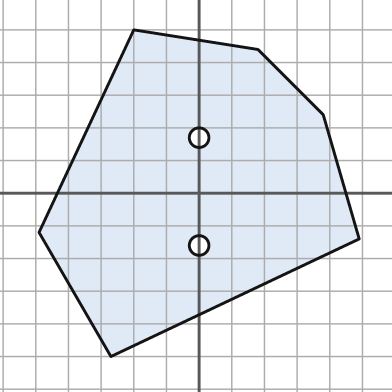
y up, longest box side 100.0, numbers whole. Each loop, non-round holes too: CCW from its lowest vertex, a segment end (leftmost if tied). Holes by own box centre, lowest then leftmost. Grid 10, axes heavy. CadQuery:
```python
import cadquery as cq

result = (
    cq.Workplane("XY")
    .moveTo(-27.0, -50.0)
    .lineTo(49.0, -14.0)
    .lineTo(38.0, 24.0)
    .lineTo(18.0, 44.0)
    .lineTo(-20.0, 50.0)
    .lineTo(-49.0, -12.0)
    .close()
    .moveTo(0.0, -16.0)
    .circle(3.0)
    .moveTo(0.0, 17.0)
    .circle(3.0)
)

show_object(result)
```